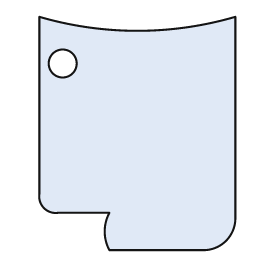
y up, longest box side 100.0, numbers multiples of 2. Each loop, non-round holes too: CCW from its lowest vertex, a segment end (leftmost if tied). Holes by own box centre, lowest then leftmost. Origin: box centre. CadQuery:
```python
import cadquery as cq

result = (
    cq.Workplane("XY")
    .moveTo(-12.0, -50.0)
    .lineTo(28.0, -50.0)
    .threePointArc((38.0, -46.0), (42.0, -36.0))
    .lineTo(42.0, 50.0)
    .threePointArc((0.0, 44.0), (-42.0, 50.0))
    .lineTo(-42.0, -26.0)
    .threePointArc((-40.0, -32.0), (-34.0, -34.0))
    .lineTo(-12.0, -34.0)
    .threePointArc((-14.0, -42.0), (-12.0, -50.0))
    .close()
    .moveTo(-32.0, 30.0)
    .circle(6.0)
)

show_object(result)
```